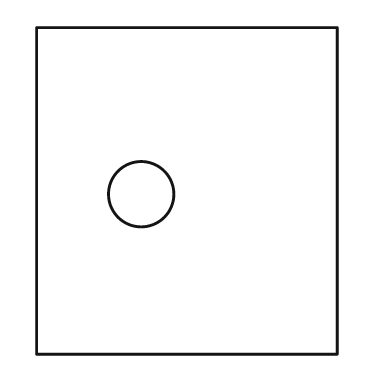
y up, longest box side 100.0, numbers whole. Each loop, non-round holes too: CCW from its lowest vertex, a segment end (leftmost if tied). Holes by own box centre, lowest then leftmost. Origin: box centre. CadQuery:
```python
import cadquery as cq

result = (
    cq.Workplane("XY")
    .moveTo(-46.0, -50.0)
    .lineTo(46.0, -50.0)
    .lineTo(46.0, 50.0)
    .lineTo(-46.0, 50.0)
    .close()
    .moveTo(-14.0, -1.0)
    .circle(10.0)
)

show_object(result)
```